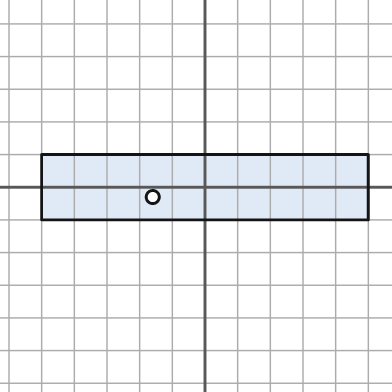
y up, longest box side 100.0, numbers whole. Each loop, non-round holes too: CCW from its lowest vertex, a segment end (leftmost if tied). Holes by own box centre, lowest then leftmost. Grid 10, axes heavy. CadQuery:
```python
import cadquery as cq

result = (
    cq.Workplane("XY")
    .moveTo(-50.0, -10.0)
    .lineTo(50.0, -10.0)
    .lineTo(50.0, 10.0)
    .lineTo(-50.0, 10.0)
    .close()
    .moveTo(-16.0, -3.0)
    .circle(2.0)
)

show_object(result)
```